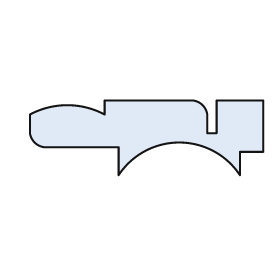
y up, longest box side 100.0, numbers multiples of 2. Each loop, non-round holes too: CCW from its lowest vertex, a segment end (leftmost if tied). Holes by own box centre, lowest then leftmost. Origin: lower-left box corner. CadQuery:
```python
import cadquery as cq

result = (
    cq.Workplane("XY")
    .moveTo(38.0, 0.0)
    .threePointArc((64.0, 14.0), (90.0, 0.0))
    .lineTo(90.0, 10.0)
    .lineTo(100.0, 10.0)
    .lineTo(100.0, 32.0)
    .lineTo(80.0, 32.0)
    .lineTo(80.0, 18.0)
    .lineTo(76.0, 18.0)
    .lineTo(76.0, 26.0)
    .threePointArc((74.0, 30.0), (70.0, 32.0))
    .lineTo(32.0, 32.0)
    .lineTo(32.0, 26.0)
    .threePointArc((16.0, 30.0), (0.0, 26.0))
    .lineTo(0.0, 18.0)
    .threePointArc((2.0, 14.0), (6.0, 12.0))
    .lineTo(38.0, 12.0)
    .close()
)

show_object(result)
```